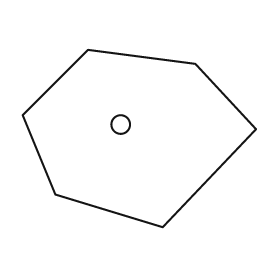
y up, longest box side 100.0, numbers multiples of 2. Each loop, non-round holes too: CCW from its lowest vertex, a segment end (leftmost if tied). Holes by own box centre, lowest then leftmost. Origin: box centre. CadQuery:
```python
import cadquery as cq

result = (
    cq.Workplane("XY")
    .moveTo(10.0, -38.0)
    .lineTo(50.0, 4.0)
    .lineTo(24.0, 32.0)
    .lineTo(-22.0, 38.0)
    .lineTo(-50.0, 10.0)
    .lineTo(-36.0, -24.0)
    .close()
    .moveTo(-8.0, 6.0)
    .circle(4.0)
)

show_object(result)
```